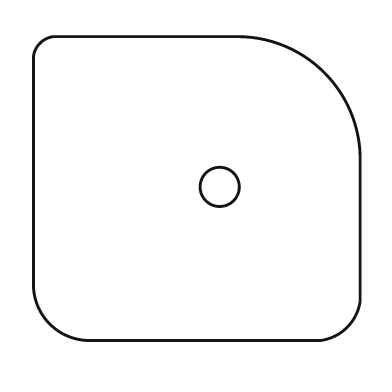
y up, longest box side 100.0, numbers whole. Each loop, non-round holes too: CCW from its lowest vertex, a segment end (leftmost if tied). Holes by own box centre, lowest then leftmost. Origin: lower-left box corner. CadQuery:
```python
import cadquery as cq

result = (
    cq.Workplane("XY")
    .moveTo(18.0, 0.0)
    .lineTo(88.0, 0.0)
    .threePointArc((96.0, 4.0), (100.0, 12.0))
    .lineTo(100.0, 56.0)
    .threePointArc((89.0, 82.0), (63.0, 93.0))
    .lineTo(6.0, 93.0)
    .threePointArc((2.0, 91.0), (0.0, 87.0))
    .lineTo(0.0, 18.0)
    .threePointArc((5.0, 5.0), (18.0, 0.0))
    .close()
    .moveTo(57.0, 47.0)
    .circle(6.0)
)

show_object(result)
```